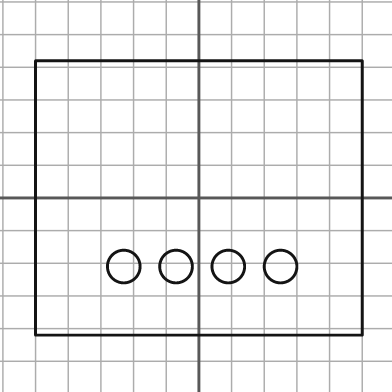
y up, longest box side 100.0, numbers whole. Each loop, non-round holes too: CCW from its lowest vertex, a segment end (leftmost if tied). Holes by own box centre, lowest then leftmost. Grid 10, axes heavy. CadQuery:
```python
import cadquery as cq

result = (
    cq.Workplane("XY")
    .moveTo(-50.0, -42.0)
    .lineTo(50.0, -42.0)
    .lineTo(50.0, 42.0)
    .lineTo(-50.0, 42.0)
    .close()
    .moveTo(-23.0, -21.0)
    .circle(5.0)
    .moveTo(-7.0, -21.0)
    .circle(5.0)
    .moveTo(9.0, -21.0)
    .circle(5.0)
    .moveTo(25.0, -21.0)
    .circle(5.0)
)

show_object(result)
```